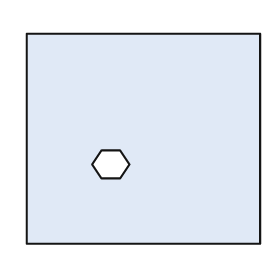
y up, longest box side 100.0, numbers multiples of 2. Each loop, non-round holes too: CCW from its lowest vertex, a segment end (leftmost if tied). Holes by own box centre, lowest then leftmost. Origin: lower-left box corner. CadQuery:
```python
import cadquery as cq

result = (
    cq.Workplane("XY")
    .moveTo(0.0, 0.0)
    .lineTo(100.0, 0.0)
    .lineTo(100.0, 90.0)
    .lineTo(0.0, 90.0)
    .close()
    .moveTo(32.0, 28.0)
    .lineTo(40.0, 28.0)
    .lineTo(44.0, 34.0)
    .lineTo(40.0, 40.0)
    .lineTo(32.0, 40.0)
    .lineTo(28.0, 34.0)
    .close()
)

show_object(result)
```